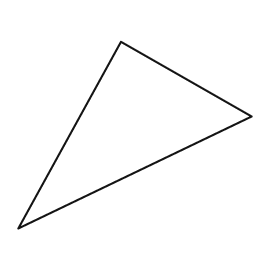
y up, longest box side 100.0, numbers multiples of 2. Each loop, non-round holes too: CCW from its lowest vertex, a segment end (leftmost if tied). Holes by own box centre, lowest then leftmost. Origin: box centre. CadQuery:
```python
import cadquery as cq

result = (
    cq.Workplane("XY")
    .moveTo(-50.0, -40.0)
    .lineTo(50.0, 8.0)
    .lineTo(-6.0, 40.0)
    .close()
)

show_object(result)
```